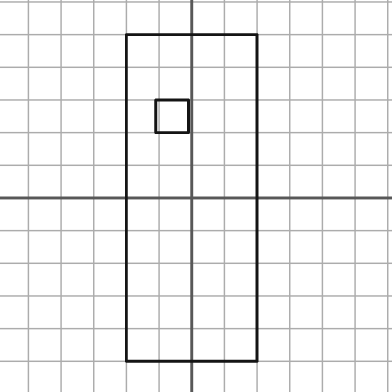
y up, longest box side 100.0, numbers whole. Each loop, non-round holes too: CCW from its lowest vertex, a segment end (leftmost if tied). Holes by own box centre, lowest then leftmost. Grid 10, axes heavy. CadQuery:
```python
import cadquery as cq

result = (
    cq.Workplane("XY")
    .moveTo(-20.0, -50.0)
    .lineTo(20.0, -50.0)
    .lineTo(20.0, 50.0)
    .lineTo(-20.0, 50.0)
    .close()
    .moveTo(-11.0, 20.0)
    .lineTo(-1.0, 20.0)
    .lineTo(-1.0, 30.0)
    .lineTo(-11.0, 30.0)
    .close()
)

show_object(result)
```